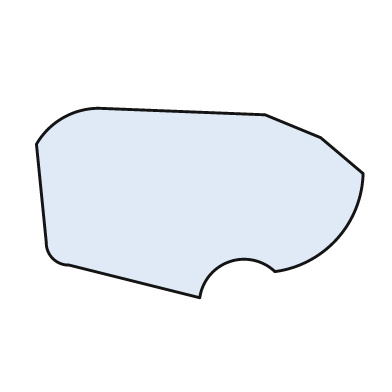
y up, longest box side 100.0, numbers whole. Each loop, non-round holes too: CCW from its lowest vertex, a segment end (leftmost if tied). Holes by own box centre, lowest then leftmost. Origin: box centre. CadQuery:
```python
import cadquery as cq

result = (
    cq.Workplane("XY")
    .moveTo(0.0, -29.0)
    .threePointArc((9.0, -18.0), (23.0, -21.0))
    .threePointArc((42.0, -11.0), (50.0, 9.0))
    .lineTo(37.0, 20.0)
    .lineTo(20.0, 27.0)
    .lineTo(-31.0, 29.0)
    .threePointArc((-42.0, 26.0), (-50.0, 18.0))
    .lineTo(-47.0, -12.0)
    .threePointArc((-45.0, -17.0), (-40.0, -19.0))
    .close()
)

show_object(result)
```